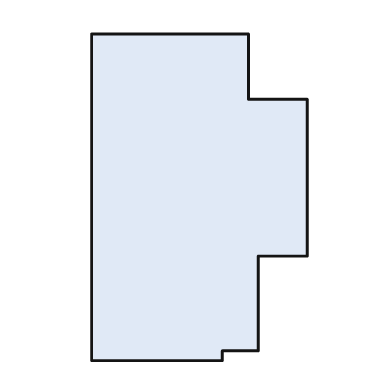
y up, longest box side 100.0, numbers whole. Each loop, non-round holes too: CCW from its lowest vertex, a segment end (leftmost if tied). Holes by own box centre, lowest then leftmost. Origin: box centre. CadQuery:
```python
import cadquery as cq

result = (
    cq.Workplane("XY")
    .moveTo(-33.0, -50.0)
    .lineTo(7.0, -50.0)
    .lineTo(7.0, -47.0)
    .lineTo(18.0, -47.0)
    .lineTo(18.0, -18.0)
    .lineTo(33.0, -18.0)
    .lineTo(33.0, 30.0)
    .lineTo(15.0, 30.0)
    .lineTo(15.0, 50.0)
    .lineTo(-33.0, 50.0)
    .close()
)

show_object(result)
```